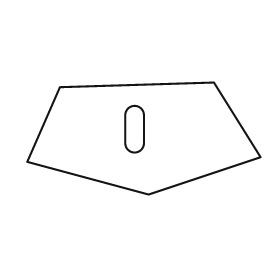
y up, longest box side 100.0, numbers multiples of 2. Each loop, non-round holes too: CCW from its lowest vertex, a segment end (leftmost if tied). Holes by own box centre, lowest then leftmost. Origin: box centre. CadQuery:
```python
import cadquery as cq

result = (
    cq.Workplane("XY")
    .moveTo(2.0, -24.0)
    .lineTo(50.0, -8.0)
    .lineTo(30.0, 24.0)
    .lineTo(-36.0, 22.0)
    .lineTo(-50.0, -10.0)
    .close()
    .moveTo(-8.0, -2.0)
    .threePointArc((-4.0, -6.0), (0.0, -2.0))
    .lineTo(0.0, 10.0)
    .threePointArc((-4.0, 14.0), (-8.0, 10.0))
    .close()
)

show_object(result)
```